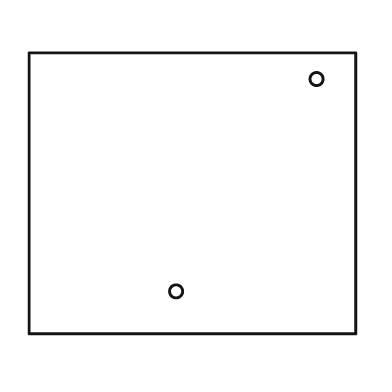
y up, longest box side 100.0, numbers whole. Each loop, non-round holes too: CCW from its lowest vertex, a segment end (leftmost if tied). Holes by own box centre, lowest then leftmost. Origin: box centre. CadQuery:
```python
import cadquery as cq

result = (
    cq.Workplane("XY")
    .moveTo(-50.0, -43.0)
    .lineTo(50.0, -43.0)
    .lineTo(50.0, 43.0)
    .lineTo(-50.0, 43.0)
    .close()
    .moveTo(-5.0, -30.0)
    .circle(2.0)
    .moveTo(38.0, 35.0)
    .circle(2.0)
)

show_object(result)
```